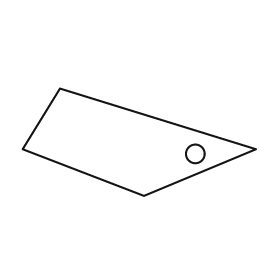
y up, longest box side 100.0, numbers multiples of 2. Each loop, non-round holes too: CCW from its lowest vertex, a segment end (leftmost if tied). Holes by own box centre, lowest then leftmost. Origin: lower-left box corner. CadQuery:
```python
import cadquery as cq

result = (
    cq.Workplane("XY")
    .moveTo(52.0, 0.0)
    .lineTo(100.0, 20.0)
    .lineTo(16.0, 46.0)
    .lineTo(0.0, 20.0)
    .close()
    .moveTo(74.0, 18.0)
    .circle(4.0)
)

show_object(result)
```